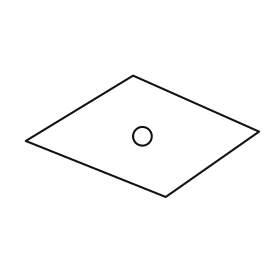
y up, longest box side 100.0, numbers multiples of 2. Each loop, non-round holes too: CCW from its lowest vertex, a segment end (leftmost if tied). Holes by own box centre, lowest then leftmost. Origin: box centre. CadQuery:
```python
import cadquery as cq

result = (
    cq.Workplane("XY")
    .moveTo(10.0, -26.0)
    .lineTo(50.0, 2.0)
    .lineTo(-4.0, 26.0)
    .lineTo(-50.0, -2.0)
    .close()
    .moveTo(0.0, 0.0)
    .circle(4.0)
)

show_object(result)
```